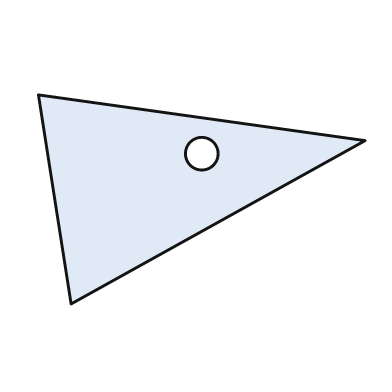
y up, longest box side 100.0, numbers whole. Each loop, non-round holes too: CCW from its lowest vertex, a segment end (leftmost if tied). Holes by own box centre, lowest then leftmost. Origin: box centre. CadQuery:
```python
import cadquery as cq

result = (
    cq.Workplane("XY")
    .moveTo(-40.0, -32.0)
    .lineTo(50.0, 18.0)
    .lineTo(-50.0, 32.0)
    .close()
    .moveTo(0.0, 14.0)
    .circle(5.0)
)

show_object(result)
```